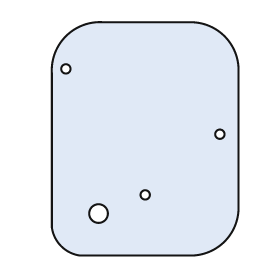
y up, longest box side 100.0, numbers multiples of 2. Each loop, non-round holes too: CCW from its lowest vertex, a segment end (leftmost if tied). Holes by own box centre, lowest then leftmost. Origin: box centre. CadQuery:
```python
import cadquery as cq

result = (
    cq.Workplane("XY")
    .moveTo(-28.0, -50.0)
    .lineTo(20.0, -50.0)
    .threePointArc((34.0, -44.0), (40.0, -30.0))
    .lineTo(40.0, 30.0)
    .threePointArc((34.0, 44.0), (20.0, 50.0))
    .lineTo(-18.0, 50.0)
    .threePointArc((-34.0, 44.0), (-40.0, 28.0))
    .lineTo(-40.0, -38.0)
    .threePointArc((-36.0, -46.0), (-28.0, -50.0))
    .close()
    .moveTo(-20.0, -32.0)
    .circle(4.0)
    .moveTo(0.0, -24.0)
    .circle(2.0)
    .moveTo(32.0, 2.0)
    .circle(2.0)
    .moveTo(-34.0, 30.0)
    .circle(2.0)
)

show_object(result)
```